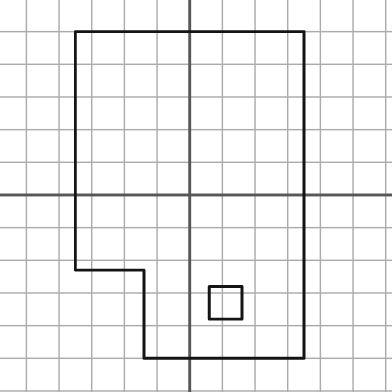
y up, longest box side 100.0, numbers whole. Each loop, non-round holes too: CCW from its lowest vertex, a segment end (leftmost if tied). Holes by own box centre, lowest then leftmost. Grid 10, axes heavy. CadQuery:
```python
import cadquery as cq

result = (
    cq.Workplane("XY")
    .moveTo(-14.0, -50.0)
    .lineTo(35.0, -50.0)
    .lineTo(35.0, 50.0)
    .lineTo(-35.0, 50.0)
    .lineTo(-35.0, -23.0)
    .lineTo(-14.0, -23.0)
    .close()
    .moveTo(6.0, -38.0)
    .lineTo(16.0, -38.0)
    .lineTo(16.0, -28.0)
    .lineTo(6.0, -28.0)
    .close()
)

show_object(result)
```